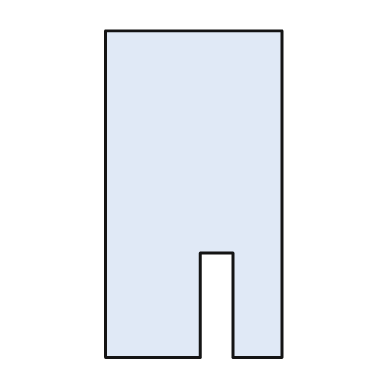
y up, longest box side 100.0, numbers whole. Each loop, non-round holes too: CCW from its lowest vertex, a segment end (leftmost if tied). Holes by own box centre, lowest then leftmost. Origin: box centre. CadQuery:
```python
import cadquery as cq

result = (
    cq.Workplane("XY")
    .moveTo(-27.0, -50.0)
    .lineTo(2.0, -50.0)
    .lineTo(2.0, -18.0)
    .lineTo(12.0, -18.0)
    .lineTo(12.0, -50.0)
    .lineTo(27.0, -50.0)
    .lineTo(27.0, 50.0)
    .lineTo(-27.0, 50.0)
    .close()
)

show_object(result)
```